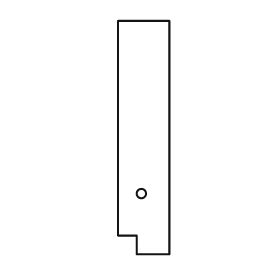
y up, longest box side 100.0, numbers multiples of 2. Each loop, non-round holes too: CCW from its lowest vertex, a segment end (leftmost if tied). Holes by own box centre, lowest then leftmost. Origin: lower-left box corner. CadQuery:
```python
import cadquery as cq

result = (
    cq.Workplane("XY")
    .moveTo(8.0, 0.0)
    .lineTo(22.0, 0.0)
    .lineTo(22.0, 100.0)
    .lineTo(0.0, 100.0)
    .lineTo(0.0, 8.0)
    .lineTo(8.0, 8.0)
    .close()
    .moveTo(10.0, 26.0)
    .circle(2.0)
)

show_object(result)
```